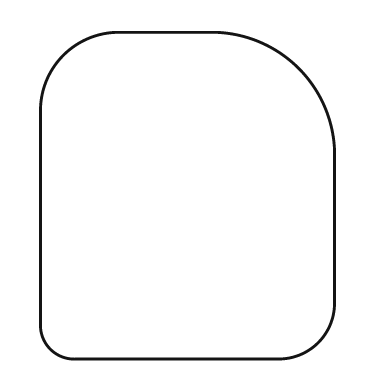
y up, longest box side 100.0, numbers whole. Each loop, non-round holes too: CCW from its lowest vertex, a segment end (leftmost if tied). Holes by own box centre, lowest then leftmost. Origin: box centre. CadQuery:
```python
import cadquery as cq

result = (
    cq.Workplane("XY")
    .moveTo(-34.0, -50.0)
    .lineTo(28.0, -50.0)
    .threePointArc((40.0, -45.0), (45.0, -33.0))
    .lineTo(45.0, 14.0)
    .threePointArc((34.0, 39.0), (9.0, 50.0))
    .lineTo(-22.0, 50.0)
    .threePointArc((-38.0, 43.0), (-45.0, 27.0))
    .lineTo(-45.0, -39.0)
    .threePointArc((-42.0, -47.0), (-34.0, -50.0))
    .close()
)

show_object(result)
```